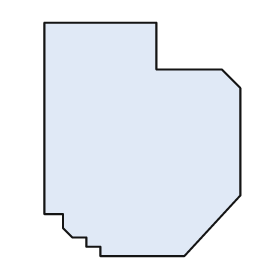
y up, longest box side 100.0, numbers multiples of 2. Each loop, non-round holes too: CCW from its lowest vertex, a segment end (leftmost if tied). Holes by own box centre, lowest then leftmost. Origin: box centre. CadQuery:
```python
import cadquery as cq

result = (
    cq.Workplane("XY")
    .moveTo(-18.0, -50.0)
    .lineTo(18.0, -50.0)
    .lineTo(42.0, -24.0)
    .lineTo(42.0, 22.0)
    .lineTo(34.0, 30.0)
    .lineTo(6.0, 30.0)
    .lineTo(6.0, 50.0)
    .lineTo(-42.0, 50.0)
    .lineTo(-42.0, -32.0)
    .lineTo(-34.0, -32.0)
    .lineTo(-34.0, -38.0)
    .lineTo(-30.0, -42.0)
    .lineTo(-24.0, -42.0)
    .lineTo(-24.0, -46.0)
    .lineTo(-18.0, -46.0)
    .close()
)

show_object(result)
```